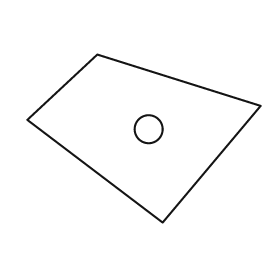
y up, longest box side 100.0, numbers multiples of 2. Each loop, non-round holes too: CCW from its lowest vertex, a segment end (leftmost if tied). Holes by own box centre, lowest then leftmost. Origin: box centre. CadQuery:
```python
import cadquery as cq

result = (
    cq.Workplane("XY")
    .moveTo(8.0, -36.0)
    .lineTo(50.0, 14.0)
    .lineTo(-20.0, 36.0)
    .lineTo(-50.0, 8.0)
    .close()
    .moveTo(2.0, 4.0)
    .circle(6.0)
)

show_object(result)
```